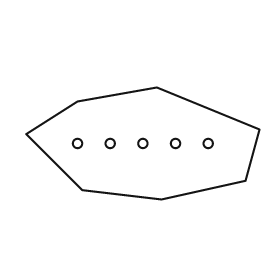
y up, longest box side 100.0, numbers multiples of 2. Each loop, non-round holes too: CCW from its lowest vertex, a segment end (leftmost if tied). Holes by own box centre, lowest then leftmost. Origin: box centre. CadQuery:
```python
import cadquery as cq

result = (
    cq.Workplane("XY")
    .moveTo(8.0, -24.0)
    .lineTo(44.0, -16.0)
    .lineTo(50.0, 6.0)
    .lineTo(6.0, 24.0)
    .lineTo(-28.0, 18.0)
    .lineTo(-50.0, 4.0)
    .lineTo(-26.0, -20.0)
    .close()
    .moveTo(-28.0, 0.0)
    .circle(2.0)
    .moveTo(-14.0, 0.0)
    .circle(2.0)
    .moveTo(0.0, 0.0)
    .circle(2.0)
    .moveTo(14.0, 0.0)
    .circle(2.0)
    .moveTo(28.0, 0.0)
    .circle(2.0)
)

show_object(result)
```